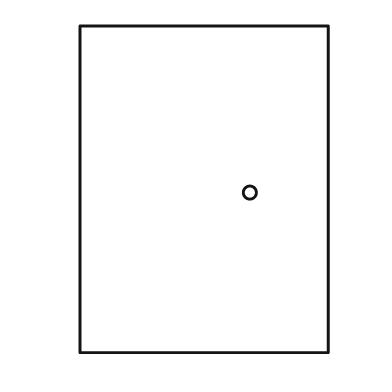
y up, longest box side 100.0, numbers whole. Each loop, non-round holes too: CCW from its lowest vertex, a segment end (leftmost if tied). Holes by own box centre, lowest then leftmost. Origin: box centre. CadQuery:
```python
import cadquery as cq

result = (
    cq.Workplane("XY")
    .moveTo(-38.0, -50.0)
    .lineTo(38.0, -50.0)
    .lineTo(38.0, 50.0)
    .lineTo(-38.0, 50.0)
    .close()
    .moveTo(14.0, -1.0)
    .circle(2.0)
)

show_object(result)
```